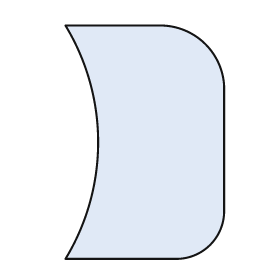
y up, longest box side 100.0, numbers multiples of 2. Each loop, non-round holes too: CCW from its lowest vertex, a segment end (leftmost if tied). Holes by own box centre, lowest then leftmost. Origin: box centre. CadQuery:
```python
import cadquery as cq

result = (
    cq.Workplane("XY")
    .moveTo(-34.0, -50.0)
    .lineTo(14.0, -50.0)
    .threePointArc((28.0, -44.0), (34.0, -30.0))
    .lineTo(34.0, 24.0)
    .threePointArc((26.0, 42.0), (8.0, 50.0))
    .lineTo(-34.0, 50.0)
    .threePointArc((-20.0, 0.0), (-34.0, -50.0))
    .close()
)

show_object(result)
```